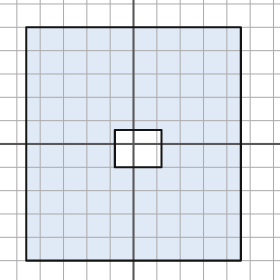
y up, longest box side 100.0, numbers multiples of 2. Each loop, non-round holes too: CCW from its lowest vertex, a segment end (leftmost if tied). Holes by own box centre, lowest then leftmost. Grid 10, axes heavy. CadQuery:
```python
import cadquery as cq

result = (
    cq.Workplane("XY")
    .moveTo(-46.0, -50.0)
    .lineTo(46.0, -50.0)
    .lineTo(46.0, 50.0)
    .lineTo(-46.0, 50.0)
    .close()
    .moveTo(-8.0, -10.0)
    .lineTo(12.0, -10.0)
    .lineTo(12.0, 6.0)
    .lineTo(-8.0, 6.0)
    .close()
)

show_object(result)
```